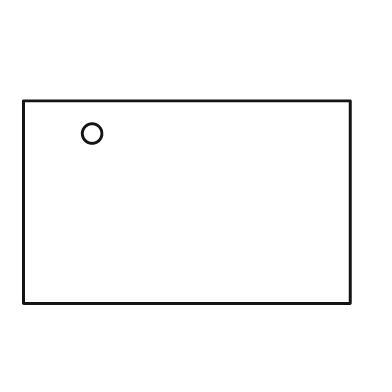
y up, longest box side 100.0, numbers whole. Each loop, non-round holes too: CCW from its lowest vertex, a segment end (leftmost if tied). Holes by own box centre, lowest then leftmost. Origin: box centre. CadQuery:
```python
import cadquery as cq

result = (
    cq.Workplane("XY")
    .moveTo(-50.0, -31.0)
    .lineTo(50.0, -31.0)
    .lineTo(50.0, 31.0)
    .lineTo(-50.0, 31.0)
    .close()
    .moveTo(-29.0, 21.0)
    .circle(3.0)
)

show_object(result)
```